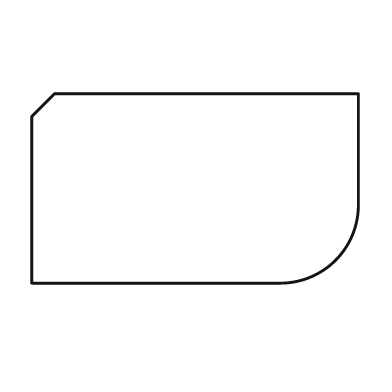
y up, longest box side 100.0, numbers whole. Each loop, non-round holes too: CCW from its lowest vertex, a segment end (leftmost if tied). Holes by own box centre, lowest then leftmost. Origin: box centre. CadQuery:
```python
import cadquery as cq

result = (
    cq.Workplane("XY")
    .moveTo(-50.0, -29.0)
    .lineTo(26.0, -29.0)
    .threePointArc((43.0, -22.0), (50.0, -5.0))
    .lineTo(50.0, 29.0)
    .lineTo(-43.0, 29.0)
    .lineTo(-50.0, 22.0)
    .close()
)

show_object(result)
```